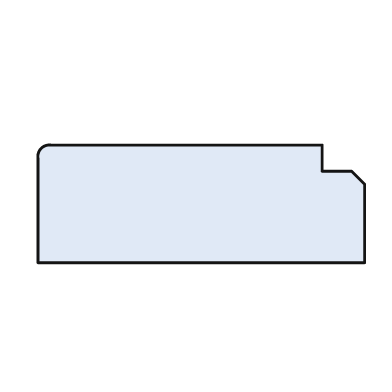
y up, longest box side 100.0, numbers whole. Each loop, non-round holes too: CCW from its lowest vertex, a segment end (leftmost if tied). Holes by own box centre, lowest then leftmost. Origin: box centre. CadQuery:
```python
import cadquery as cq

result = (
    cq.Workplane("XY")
    .moveTo(-50.0, -18.0)
    .lineTo(50.0, -18.0)
    .lineTo(50.0, 6.0)
    .lineTo(46.0, 10.0)
    .lineTo(37.0, 10.0)
    .lineTo(37.0, 18.0)
    .lineTo(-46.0, 18.0)
    .threePointArc((-49.0, 17.0), (-50.0, 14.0))
    .close()
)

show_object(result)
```